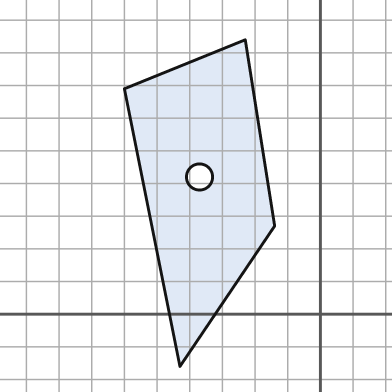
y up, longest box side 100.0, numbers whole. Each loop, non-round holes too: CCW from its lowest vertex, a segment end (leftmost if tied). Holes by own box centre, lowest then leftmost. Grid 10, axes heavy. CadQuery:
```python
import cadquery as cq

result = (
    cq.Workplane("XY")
    .moveTo(-43.0, -16.0)
    .lineTo(-14.0, 27.0)
    .lineTo(-23.0, 84.0)
    .lineTo(-60.0, 69.0)
    .close()
    .moveTo(-37.0, 42.0)
    .circle(4.0)
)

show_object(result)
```